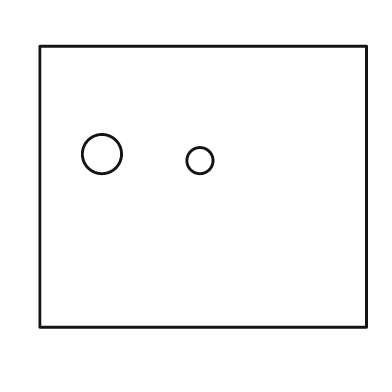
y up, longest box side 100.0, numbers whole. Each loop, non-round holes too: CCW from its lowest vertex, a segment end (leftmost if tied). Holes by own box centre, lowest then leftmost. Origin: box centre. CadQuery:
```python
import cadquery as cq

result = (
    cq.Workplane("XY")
    .moveTo(-50.0, -43.0)
    .lineTo(50.0, -43.0)
    .lineTo(50.0, 43.0)
    .lineTo(-50.0, 43.0)
    .close()
    .moveTo(-1.0, 8.0)
    .circle(4.0)
    .moveTo(-31.0, 10.0)
    .circle(6.0)
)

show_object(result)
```